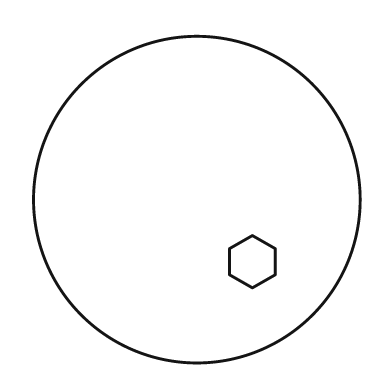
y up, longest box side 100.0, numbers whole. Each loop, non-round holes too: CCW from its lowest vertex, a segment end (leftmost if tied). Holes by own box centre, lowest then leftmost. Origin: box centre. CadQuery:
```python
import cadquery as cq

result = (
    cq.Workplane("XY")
    .moveTo(0.0, 0.0)
    .circle(50.0)
    .moveTo(17.0, -27.0)
    .lineTo(24.0, -23.0)
    .lineTo(24.0, -15.0)
    .lineTo(17.0, -11.0)
    .lineTo(10.0, -15.0)
    .lineTo(10.0, -23.0)
    .close()
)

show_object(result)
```